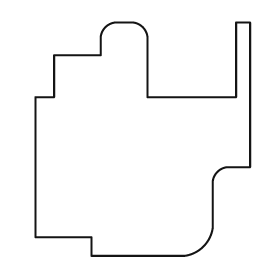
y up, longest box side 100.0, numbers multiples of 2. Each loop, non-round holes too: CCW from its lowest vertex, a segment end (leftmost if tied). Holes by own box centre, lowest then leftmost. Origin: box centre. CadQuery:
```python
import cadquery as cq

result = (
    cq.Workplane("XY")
    .moveTo(-22.0, -50.0)
    .lineTo(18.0, -50.0)
    .threePointArc((26.0, -46.0), (30.0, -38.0))
    .lineTo(30.0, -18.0)
    .threePointArc((32.0, -14.0), (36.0, -12.0))
    .lineTo(46.0, -12.0)
    .lineTo(46.0, 50.0)
    .lineTo(40.0, 50.0)
    .lineTo(40.0, 18.0)
    .lineTo(2.0, 18.0)
    .lineTo(2.0, 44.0)
    .threePointArc((0.0, 48.0), (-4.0, 50.0))
    .lineTo(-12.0, 50.0)
    .threePointArc((-16.0, 48.0), (-18.0, 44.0))
    .lineTo(-18.0, 36.0)
    .lineTo(-38.0, 36.0)
    .lineTo(-38.0, 18.0)
    .lineTo(-46.0, 18.0)
    .lineTo(-46.0, -42.0)
    .lineTo(-22.0, -42.0)
    .close()
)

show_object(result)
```